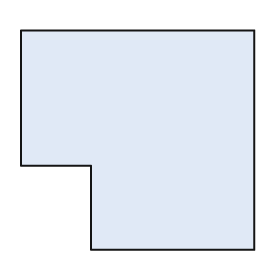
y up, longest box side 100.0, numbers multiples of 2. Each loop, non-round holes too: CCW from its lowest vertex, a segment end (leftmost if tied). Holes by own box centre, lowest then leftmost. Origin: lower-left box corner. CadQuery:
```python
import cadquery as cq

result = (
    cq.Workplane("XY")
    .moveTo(30.0, 0.0)
    .lineTo(100.0, 0.0)
    .lineTo(100.0, 94.0)
    .lineTo(0.0, 94.0)
    .lineTo(0.0, 36.0)
    .lineTo(30.0, 36.0)
    .close()
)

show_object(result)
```